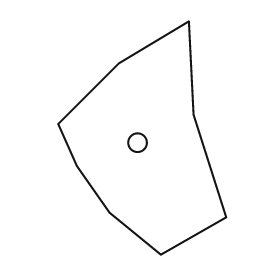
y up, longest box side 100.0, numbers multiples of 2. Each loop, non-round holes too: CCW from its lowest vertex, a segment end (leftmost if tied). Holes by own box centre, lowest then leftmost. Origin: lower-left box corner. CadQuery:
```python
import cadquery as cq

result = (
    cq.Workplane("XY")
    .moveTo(44.0, 0.0)
    .lineTo(72.0, 16.0)
    .lineTo(58.0, 60.0)
    .lineTo(56.0, 100.0)
    .lineTo(26.0, 82.0)
    .lineTo(0.0, 56.0)
    .lineTo(8.0, 38.0)
    .lineTo(22.0, 18.0)
    .close()
    .moveTo(34.0, 48.0)
    .circle(4.0)
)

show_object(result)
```